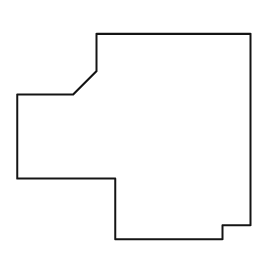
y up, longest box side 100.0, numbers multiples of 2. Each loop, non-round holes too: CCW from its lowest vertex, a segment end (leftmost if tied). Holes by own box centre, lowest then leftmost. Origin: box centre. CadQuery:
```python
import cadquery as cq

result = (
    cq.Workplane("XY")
    .moveTo(-8.0, -44.0)
    .lineTo(38.0, -44.0)
    .lineTo(38.0, -38.0)
    .lineTo(50.0, -38.0)
    .lineTo(50.0, 44.0)
    .lineTo(-16.0, 44.0)
    .lineTo(-16.0, 28.0)
    .lineTo(-26.0, 18.0)
    .lineTo(-50.0, 18.0)
    .lineTo(-50.0, -18.0)
    .lineTo(-8.0, -18.0)
    .close()
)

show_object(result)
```